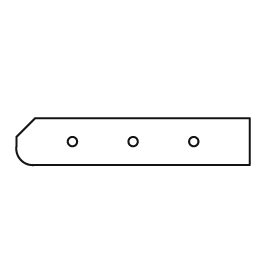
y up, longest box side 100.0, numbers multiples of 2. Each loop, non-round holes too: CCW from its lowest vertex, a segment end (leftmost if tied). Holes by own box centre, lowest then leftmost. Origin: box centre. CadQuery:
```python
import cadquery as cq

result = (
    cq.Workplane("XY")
    .moveTo(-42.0, -10.0)
    .lineTo(50.0, -10.0)
    .lineTo(50.0, 10.0)
    .lineTo(-42.0, 10.0)
    .lineTo(-50.0, 2.0)
    .lineTo(-50.0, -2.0)
    .threePointArc((-48.0, -8.0), (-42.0, -10.0))
    .close()
    .moveTo(-26.0, 0.0)
    .circle(2.0)
    .moveTo(0.0, 0.0)
    .circle(2.0)
    .moveTo(26.0, 0.0)
    .circle(2.0)
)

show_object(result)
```